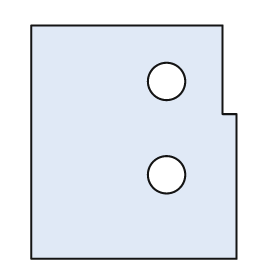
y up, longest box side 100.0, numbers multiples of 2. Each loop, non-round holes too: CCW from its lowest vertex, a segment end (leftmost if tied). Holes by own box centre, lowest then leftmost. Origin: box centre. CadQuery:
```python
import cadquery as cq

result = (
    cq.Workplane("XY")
    .moveTo(-44.0, -50.0)
    .lineTo(44.0, -50.0)
    .lineTo(44.0, 12.0)
    .lineTo(38.0, 12.0)
    .lineTo(38.0, 50.0)
    .lineTo(-44.0, 50.0)
    .close()
    .moveTo(14.0, -14.0)
    .circle(8.0)
    .moveTo(14.0, 26.0)
    .circle(8.0)
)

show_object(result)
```